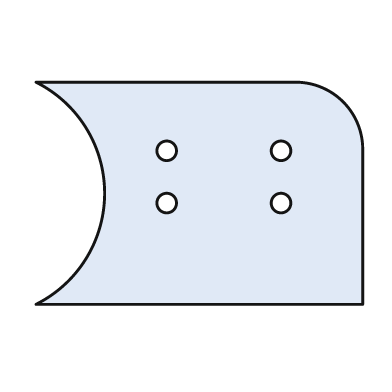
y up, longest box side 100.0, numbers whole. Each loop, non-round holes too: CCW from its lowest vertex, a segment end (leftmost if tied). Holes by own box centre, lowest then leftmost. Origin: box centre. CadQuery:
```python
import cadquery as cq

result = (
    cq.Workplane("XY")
    .moveTo(-50.0, -34.0)
    .lineTo(50.0, -34.0)
    .lineTo(50.0, 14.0)
    .threePointArc((44.0, 28.0), (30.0, 34.0))
    .lineTo(-50.0, 34.0)
    .threePointArc((-29.0, 0.0), (-50.0, -34.0))
    .close()
    .moveTo(-10.0, -3.0)
    .circle(3.0)
    .moveTo(25.0, -3.0)
    .circle(3.0)
    .moveTo(-10.0, 13.0)
    .circle(3.0)
    .moveTo(25.0, 13.0)
    .circle(3.0)
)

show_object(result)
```